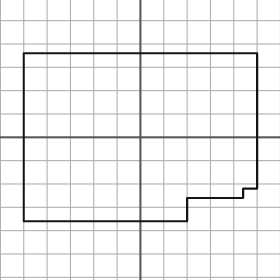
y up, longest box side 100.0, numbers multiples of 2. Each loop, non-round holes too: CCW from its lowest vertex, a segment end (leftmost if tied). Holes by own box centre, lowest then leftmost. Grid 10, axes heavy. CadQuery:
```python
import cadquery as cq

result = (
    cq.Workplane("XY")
    .moveTo(-50.0, -36.0)
    .lineTo(20.0, -36.0)
    .lineTo(20.0, -26.0)
    .lineTo(44.0, -26.0)
    .lineTo(44.0, -22.0)
    .lineTo(50.0, -22.0)
    .lineTo(50.0, 36.0)
    .lineTo(-50.0, 36.0)
    .close()
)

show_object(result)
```